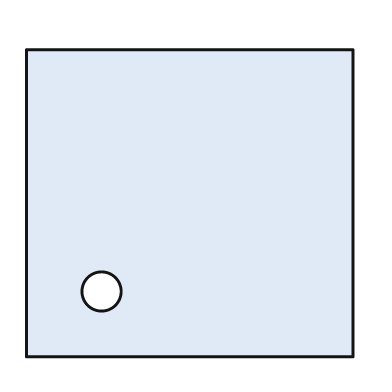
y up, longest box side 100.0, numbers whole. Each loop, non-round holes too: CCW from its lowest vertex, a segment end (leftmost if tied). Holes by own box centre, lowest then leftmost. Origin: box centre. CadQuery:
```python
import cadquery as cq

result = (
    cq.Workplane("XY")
    .moveTo(-50.0, -47.0)
    .lineTo(50.0, -47.0)
    .lineTo(50.0, 47.0)
    .lineTo(-50.0, 47.0)
    .close()
    .moveTo(-27.0, -27.0)
    .circle(6.0)
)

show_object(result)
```